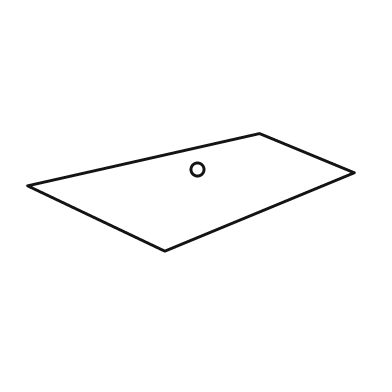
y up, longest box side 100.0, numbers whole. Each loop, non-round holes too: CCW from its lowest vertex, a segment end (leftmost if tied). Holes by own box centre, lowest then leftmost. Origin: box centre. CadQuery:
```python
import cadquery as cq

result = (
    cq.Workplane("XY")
    .moveTo(-8.0, -18.0)
    .lineTo(50.0, 6.0)
    .lineTo(21.0, 18.0)
    .lineTo(-50.0, 2.0)
    .close()
    .moveTo(2.0, 7.0)
    .circle(2.0)
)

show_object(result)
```